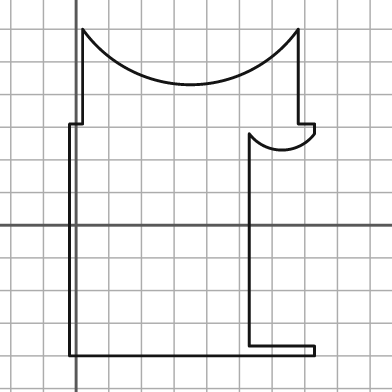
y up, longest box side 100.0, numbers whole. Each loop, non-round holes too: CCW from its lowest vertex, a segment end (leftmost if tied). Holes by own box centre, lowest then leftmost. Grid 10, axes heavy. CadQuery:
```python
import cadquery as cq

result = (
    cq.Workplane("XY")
    .moveTo(-2.0, -40.0)
    .lineTo(73.0, -40.0)
    .lineTo(73.0, -37.0)
    .lineTo(53.0, -37.0)
    .lineTo(53.0, 28.0)
    .threePointArc((63.0, 23.0), (73.0, 28.0))
    .lineTo(73.0, 31.0)
    .lineTo(68.0, 31.0)
    .lineTo(68.0, 60.0)
    .threePointArc((35.0, 43.0), (2.0, 60.0))
    .lineTo(2.0, 31.0)
    .lineTo(-2.0, 31.0)
    .close()
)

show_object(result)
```